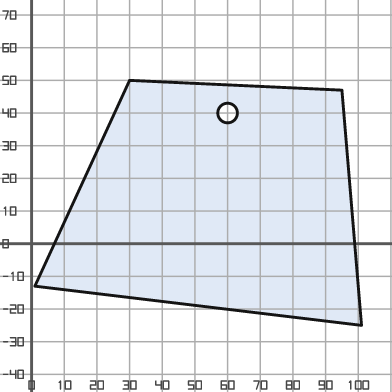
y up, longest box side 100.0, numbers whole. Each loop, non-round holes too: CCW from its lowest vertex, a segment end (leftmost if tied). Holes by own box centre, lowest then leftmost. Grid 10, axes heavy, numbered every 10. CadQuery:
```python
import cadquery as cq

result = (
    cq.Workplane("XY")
    .moveTo(101.0, -25.0)
    .lineTo(95.0, 47.0)
    .lineTo(30.0, 50.0)
    .lineTo(1.0, -13.0)
    .close()
    .moveTo(60.0, 40.0)
    .circle(3.0)
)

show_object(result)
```